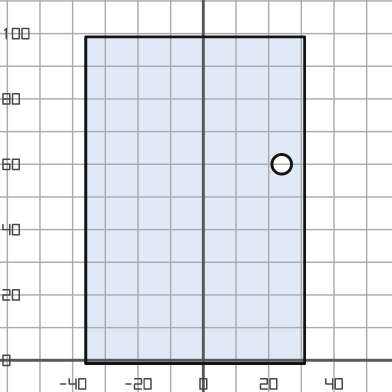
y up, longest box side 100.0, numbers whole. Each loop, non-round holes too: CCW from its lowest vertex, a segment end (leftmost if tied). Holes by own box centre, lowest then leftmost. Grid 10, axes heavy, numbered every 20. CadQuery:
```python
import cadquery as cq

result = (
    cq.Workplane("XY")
    .moveTo(-36.0, -1.0)
    .lineTo(31.0, -1.0)
    .lineTo(31.0, 99.0)
    .lineTo(-36.0, 99.0)
    .close()
    .moveTo(24.0, 60.0)
    .circle(3.0)
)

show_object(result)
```